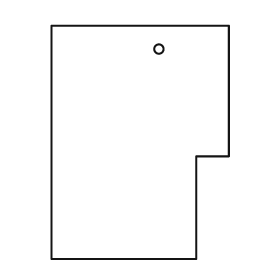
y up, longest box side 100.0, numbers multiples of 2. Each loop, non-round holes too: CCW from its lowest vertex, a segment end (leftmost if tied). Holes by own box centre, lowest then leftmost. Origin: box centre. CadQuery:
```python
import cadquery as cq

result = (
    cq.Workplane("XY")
    .moveTo(-38.0, -50.0)
    .lineTo(24.0, -50.0)
    .lineTo(24.0, -6.0)
    .lineTo(38.0, -6.0)
    .lineTo(38.0, 50.0)
    .lineTo(-38.0, 50.0)
    .close()
    .moveTo(8.0, 40.0)
    .circle(2.0)
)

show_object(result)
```